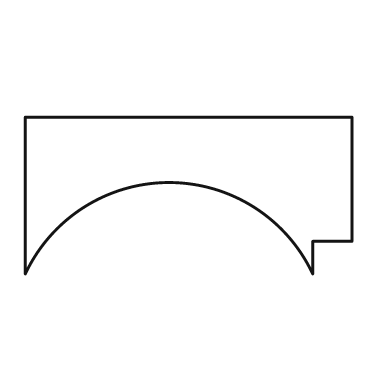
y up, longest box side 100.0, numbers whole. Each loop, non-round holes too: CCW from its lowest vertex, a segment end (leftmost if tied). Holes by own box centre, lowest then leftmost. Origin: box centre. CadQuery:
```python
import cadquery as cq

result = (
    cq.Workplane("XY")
    .moveTo(-50.0, -24.0)
    .threePointArc((-6.0, 4.0), (38.0, -24.0))
    .lineTo(38.0, -14.0)
    .lineTo(50.0, -14.0)
    .lineTo(50.0, 24.0)
    .lineTo(-50.0, 24.0)
    .close()
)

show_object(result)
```